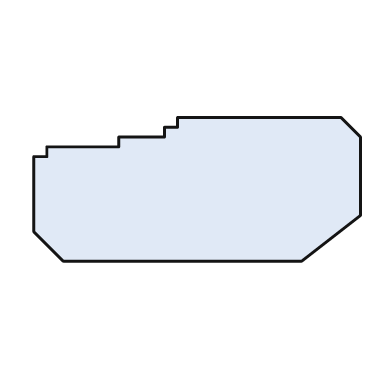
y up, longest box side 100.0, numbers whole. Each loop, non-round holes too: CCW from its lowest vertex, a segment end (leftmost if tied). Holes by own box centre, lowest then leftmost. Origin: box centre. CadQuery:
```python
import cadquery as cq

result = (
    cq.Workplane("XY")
    .moveTo(-41.0, -22.0)
    .lineTo(32.0, -22.0)
    .lineTo(50.0, -8.0)
    .lineTo(50.0, 16.0)
    .lineTo(44.0, 22.0)
    .lineTo(-6.0, 22.0)
    .lineTo(-6.0, 19.0)
    .lineTo(-10.0, 19.0)
    .lineTo(-10.0, 16.0)
    .lineTo(-24.0, 16.0)
    .lineTo(-24.0, 13.0)
    .lineTo(-46.0, 13.0)
    .lineTo(-46.0, 10.0)
    .lineTo(-50.0, 10.0)
    .lineTo(-50.0, -13.0)
    .close()
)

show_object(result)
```